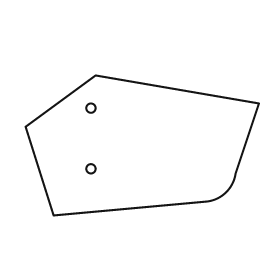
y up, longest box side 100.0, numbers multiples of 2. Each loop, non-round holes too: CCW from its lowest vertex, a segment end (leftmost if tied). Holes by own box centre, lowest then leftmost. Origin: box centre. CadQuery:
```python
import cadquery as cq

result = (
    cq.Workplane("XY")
    .moveTo(-38.0, -30.0)
    .lineTo(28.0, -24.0)
    .threePointArc((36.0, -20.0), (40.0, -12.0))
    .lineTo(50.0, 18.0)
    .lineTo(-20.0, 30.0)
    .lineTo(-50.0, 8.0)
    .close()
    .moveTo(-22.0, -10.0)
    .circle(2.0)
    .moveTo(-22.0, 16.0)
    .circle(2.0)
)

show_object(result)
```